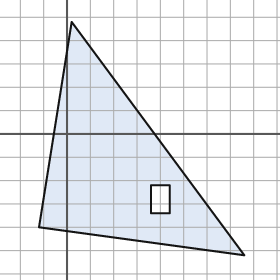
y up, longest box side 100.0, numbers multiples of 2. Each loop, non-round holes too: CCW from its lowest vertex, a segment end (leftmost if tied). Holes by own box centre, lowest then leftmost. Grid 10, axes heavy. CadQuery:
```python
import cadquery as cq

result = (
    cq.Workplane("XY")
    .moveTo(76.0, -52.0)
    .lineTo(2.0, 48.0)
    .lineTo(-12.0, -40.0)
    .close()
    .moveTo(36.0, -34.0)
    .lineTo(44.0, -34.0)
    .lineTo(44.0, -22.0)
    .lineTo(36.0, -22.0)
    .close()
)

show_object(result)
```